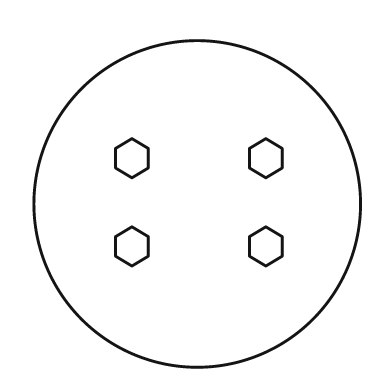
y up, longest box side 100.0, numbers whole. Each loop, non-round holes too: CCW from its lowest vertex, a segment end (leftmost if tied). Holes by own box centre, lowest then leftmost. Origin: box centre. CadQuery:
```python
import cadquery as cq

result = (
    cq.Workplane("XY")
    .moveTo(0.0, 0.0)
    .circle(50.0)
    .moveTo(-20.0, -19.0)
    .lineTo(-15.0, -16.0)
    .lineTo(-15.0, -10.0)
    .lineTo(-20.0, -7.0)
    .lineTo(-25.0, -10.0)
    .lineTo(-25.0, -16.0)
    .close()
    .moveTo(21.0, -19.0)
    .lineTo(26.0, -16.0)
    .lineTo(26.0, -10.0)
    .lineTo(21.0, -7.0)
    .lineTo(16.0, -10.0)
    .lineTo(16.0, -16.0)
    .close()
    .moveTo(-20.0, 8.0)
    .lineTo(-15.0, 11.0)
    .lineTo(-15.0, 17.0)
    .lineTo(-20.0, 20.0)
    .lineTo(-25.0, 17.0)
    .lineTo(-25.0, 11.0)
    .close()
    .moveTo(21.0, 8.0)
    .lineTo(26.0, 11.0)
    .lineTo(26.0, 17.0)
    .lineTo(21.0, 20.0)
    .lineTo(16.0, 17.0)
    .lineTo(16.0, 11.0)
    .close()
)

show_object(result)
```